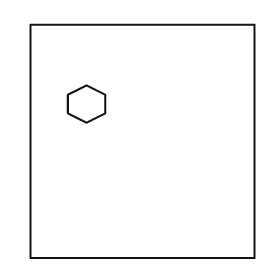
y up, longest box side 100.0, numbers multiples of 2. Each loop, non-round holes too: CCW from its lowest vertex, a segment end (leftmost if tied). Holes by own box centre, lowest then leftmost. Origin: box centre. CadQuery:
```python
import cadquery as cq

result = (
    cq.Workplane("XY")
    .moveTo(-48.0, -50.0)
    .lineTo(48.0, -50.0)
    .lineTo(48.0, 50.0)
    .lineTo(-48.0, 50.0)
    .close()
    .moveTo(-24.0, 8.0)
    .lineTo(-16.0, 12.0)
    .lineTo(-16.0, 20.0)
    .lineTo(-24.0, 24.0)
    .lineTo(-32.0, 20.0)
    .lineTo(-32.0, 12.0)
    .close()
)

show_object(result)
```